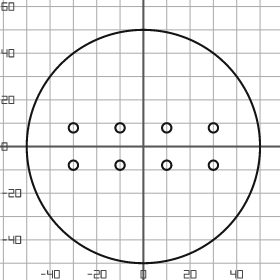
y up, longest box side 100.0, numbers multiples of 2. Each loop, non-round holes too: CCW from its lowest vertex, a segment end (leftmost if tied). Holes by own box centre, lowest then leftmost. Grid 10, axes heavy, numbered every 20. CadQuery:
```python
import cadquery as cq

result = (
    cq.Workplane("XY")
    .moveTo(0.0, 0.0)
    .circle(50.0)
    .moveTo(-30.0, -8.0)
    .circle(2.0)
    .moveTo(-10.0, -8.0)
    .circle(2.0)
    .moveTo(10.0, -8.0)
    .circle(2.0)
    .moveTo(30.0, -8.0)
    .circle(2.0)
    .moveTo(-30.0, 8.0)
    .circle(2.0)
    .moveTo(-10.0, 8.0)
    .circle(2.0)
    .moveTo(10.0, 8.0)
    .circle(2.0)
    .moveTo(30.0, 8.0)
    .circle(2.0)
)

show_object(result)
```